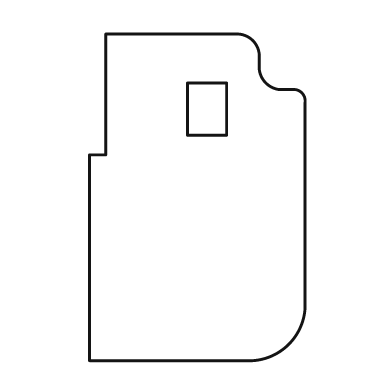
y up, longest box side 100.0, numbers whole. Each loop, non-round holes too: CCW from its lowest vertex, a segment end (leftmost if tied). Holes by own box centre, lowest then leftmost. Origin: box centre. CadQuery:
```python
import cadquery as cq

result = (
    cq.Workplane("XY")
    .moveTo(-33.0, -50.0)
    .lineTo(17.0, -50.0)
    .threePointArc((28.0, -45.0), (33.0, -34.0))
    .lineTo(33.0, 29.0)
    .threePointArc((32.0, 32.0), (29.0, 33.0))
    .lineTo(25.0, 33.0)
    .threePointArc((21.0, 35.0), (19.0, 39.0))
    .lineTo(19.0, 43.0)
    .threePointArc((17.0, 48.0), (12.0, 50.0))
    .lineTo(-28.0, 50.0)
    .lineTo(-28.0, 13.0)
    .lineTo(-33.0, 13.0)
    .close()
    .moveTo(-3.0, 19.0)
    .lineTo(9.0, 19.0)
    .lineTo(9.0, 35.0)
    .lineTo(-3.0, 35.0)
    .close()
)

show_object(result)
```